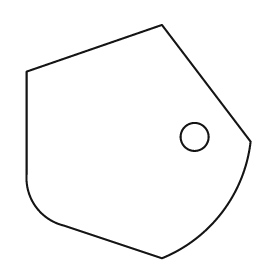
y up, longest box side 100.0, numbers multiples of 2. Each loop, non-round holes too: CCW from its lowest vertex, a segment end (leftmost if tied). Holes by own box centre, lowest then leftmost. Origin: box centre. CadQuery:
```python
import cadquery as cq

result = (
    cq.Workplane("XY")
    .moveTo(10.0, -50.0)
    .threePointArc((36.0, -30.0), (48.0, 0.0))
    .lineTo(10.0, 50.0)
    .lineTo(-48.0, 30.0)
    .lineTo(-48.0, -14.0)
    .threePointArc((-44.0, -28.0), (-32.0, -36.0))
    .close()
    .moveTo(24.0, 2.0)
    .circle(6.0)
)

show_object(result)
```